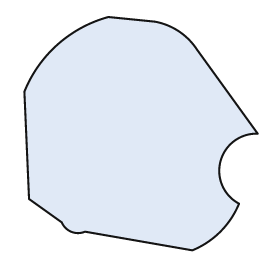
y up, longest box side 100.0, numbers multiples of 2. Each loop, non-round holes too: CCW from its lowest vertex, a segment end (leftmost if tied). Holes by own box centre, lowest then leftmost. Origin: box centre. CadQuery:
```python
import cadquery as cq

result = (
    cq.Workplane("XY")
    .moveTo(22.0, -50.0)
    .threePointArc((34.0, -42.0), (42.0, -30.0))
    .threePointArc((34.0, -12.0), (50.0, 0.0))
    .lineTo(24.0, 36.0)
    .threePointArc((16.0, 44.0), (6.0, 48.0))
    .lineTo(-14.0, 50.0)
    .threePointArc((-36.0, 38.0), (-50.0, 18.0))
    .lineTo(-48.0, -28.0)
    .lineTo(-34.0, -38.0)
    .threePointArc((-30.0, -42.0), (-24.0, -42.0))
    .close()
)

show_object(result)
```